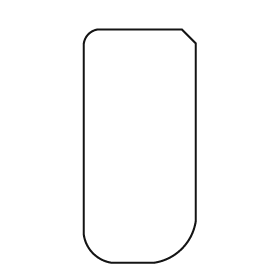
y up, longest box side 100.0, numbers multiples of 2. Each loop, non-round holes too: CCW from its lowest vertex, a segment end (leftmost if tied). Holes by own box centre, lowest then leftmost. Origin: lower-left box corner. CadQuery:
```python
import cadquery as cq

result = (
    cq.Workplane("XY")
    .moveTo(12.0, 0.0)
    .lineTo(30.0, 0.0)
    .threePointArc((42.0, 6.0), (48.0, 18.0))
    .lineTo(48.0, 94.0)
    .lineTo(42.0, 100.0)
    .lineTo(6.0, 100.0)
    .threePointArc((2.0, 98.0), (0.0, 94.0))
    .lineTo(0.0, 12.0)
    .threePointArc((4.0, 4.0), (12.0, 0.0))
    .close()
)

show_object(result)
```